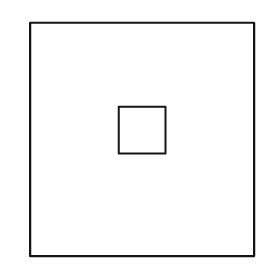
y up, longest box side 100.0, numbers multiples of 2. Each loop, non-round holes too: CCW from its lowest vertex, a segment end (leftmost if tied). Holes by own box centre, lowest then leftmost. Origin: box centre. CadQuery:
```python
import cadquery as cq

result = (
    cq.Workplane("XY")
    .moveTo(-48.0, -50.0)
    .lineTo(48.0, -50.0)
    .lineTo(48.0, 50.0)
    .lineTo(-48.0, 50.0)
    .close()
    .moveTo(-10.0, -6.0)
    .lineTo(10.0, -6.0)
    .lineTo(10.0, 14.0)
    .lineTo(-10.0, 14.0)
    .close()
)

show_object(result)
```